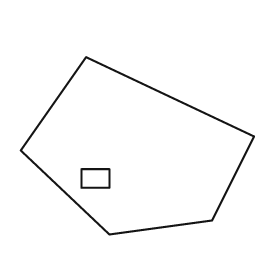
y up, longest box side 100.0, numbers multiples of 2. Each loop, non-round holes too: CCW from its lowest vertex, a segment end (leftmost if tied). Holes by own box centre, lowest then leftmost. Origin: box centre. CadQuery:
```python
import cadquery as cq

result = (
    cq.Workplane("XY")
    .moveTo(-12.0, -38.0)
    .lineTo(32.0, -32.0)
    .lineTo(50.0, 4.0)
    .lineTo(-22.0, 38.0)
    .lineTo(-50.0, -2.0)
    .close()
    .moveTo(-24.0, -18.0)
    .lineTo(-12.0, -18.0)
    .lineTo(-12.0, -10.0)
    .lineTo(-24.0, -10.0)
    .close()
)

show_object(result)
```